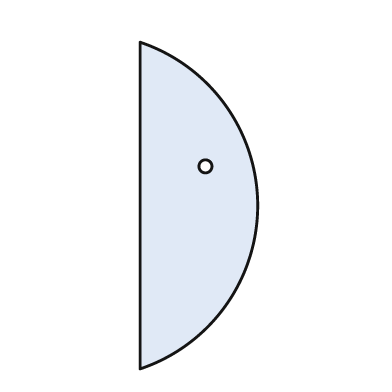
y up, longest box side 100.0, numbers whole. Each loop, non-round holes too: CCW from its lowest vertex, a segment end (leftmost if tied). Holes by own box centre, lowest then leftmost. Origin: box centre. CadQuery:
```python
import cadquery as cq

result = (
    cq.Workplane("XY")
    .moveTo(-18.0, -50.0)
    .threePointArc((18.0, 0.0), (-18.0, 50.0))
    .close()
    .moveTo(2.0, 12.0)
    .circle(2.0)
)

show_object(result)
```